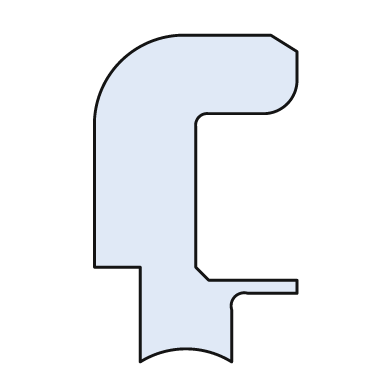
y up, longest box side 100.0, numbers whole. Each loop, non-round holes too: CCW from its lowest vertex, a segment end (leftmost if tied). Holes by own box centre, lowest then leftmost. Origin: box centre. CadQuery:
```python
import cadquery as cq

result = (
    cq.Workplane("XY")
    .moveTo(-17.0, -50.0)
    .threePointArc((-3.0, -46.0), (11.0, -50.0))
    .lineTo(11.0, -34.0)
    .threePointArc((12.0, -30.0), (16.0, -29.0))
    .lineTo(31.0, -29.0)
    .lineTo(31.0, -25.0)
    .lineTo(4.0, -25.0)
    .lineTo(0.0, -21.0)
    .lineTo(0.0, 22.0)
    .threePointArc((1.0, 25.0), (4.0, 26.0))
    .lineTo(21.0, 26.0)
    .threePointArc((28.0, 29.0), (31.0, 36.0))
    .lineTo(31.0, 45.0)
    .lineTo(23.0, 50.0)
    .lineTo(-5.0, 50.0)
    .threePointArc((-23.0, 42.0), (-31.0, 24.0))
    .lineTo(-31.0, -21.0)
    .lineTo(-17.0, -21.0)
    .close()
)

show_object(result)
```